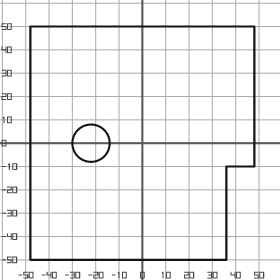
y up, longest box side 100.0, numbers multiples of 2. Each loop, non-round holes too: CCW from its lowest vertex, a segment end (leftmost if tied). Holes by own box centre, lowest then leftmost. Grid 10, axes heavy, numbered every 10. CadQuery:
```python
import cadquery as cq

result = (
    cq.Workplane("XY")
    .moveTo(-48.0, -50.0)
    .lineTo(36.0, -50.0)
    .lineTo(36.0, -10.0)
    .lineTo(48.0, -10.0)
    .lineTo(48.0, 50.0)
    .lineTo(-48.0, 50.0)
    .close()
    .moveTo(-22.0, 0.0)
    .circle(8.0)
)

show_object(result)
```